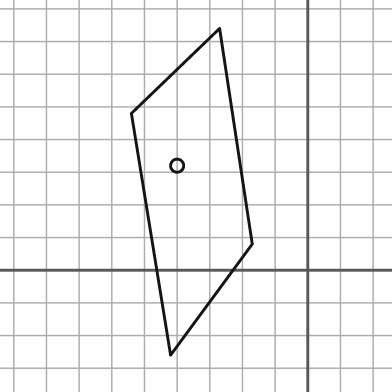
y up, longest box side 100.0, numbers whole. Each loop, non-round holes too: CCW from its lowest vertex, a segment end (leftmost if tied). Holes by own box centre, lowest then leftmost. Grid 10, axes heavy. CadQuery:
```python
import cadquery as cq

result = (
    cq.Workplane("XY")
    .moveTo(-42.0, -26.0)
    .lineTo(-17.0, 8.0)
    .lineTo(-27.0, 74.0)
    .lineTo(-54.0, 48.0)
    .close()
    .moveTo(-40.0, 32.0)
    .circle(2.0)
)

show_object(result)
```